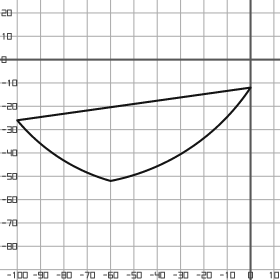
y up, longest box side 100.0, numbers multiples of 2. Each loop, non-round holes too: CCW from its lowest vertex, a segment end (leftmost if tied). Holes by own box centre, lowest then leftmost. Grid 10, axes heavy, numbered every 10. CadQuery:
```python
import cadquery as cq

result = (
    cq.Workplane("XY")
    .moveTo(-60.0, -52.0)
    .threePointArc((-26.0, -38.0), (0.0, -12.0))
    .lineTo(-100.0, -26.0)
    .threePointArc((-82.0, -42.0), (-60.0, -52.0))
    .close()
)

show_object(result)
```